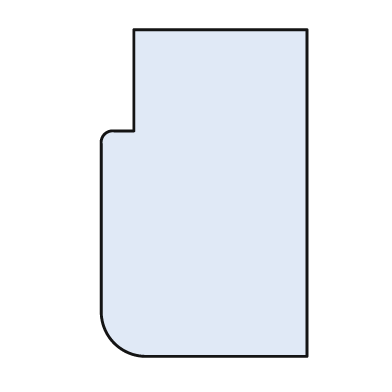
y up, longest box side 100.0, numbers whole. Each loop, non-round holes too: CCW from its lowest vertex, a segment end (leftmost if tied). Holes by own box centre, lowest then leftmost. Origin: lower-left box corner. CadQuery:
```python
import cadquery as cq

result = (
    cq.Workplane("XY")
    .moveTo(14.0, 0.0)
    .lineTo(63.0, 0.0)
    .lineTo(63.0, 100.0)
    .lineTo(10.0, 100.0)
    .lineTo(10.0, 69.0)
    .lineTo(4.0, 69.0)
    .threePointArc((1.0, 68.0), (0.0, 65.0))
    .lineTo(0.0, 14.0)
    .threePointArc((4.0, 4.0), (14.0, 0.0))
    .close()
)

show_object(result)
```